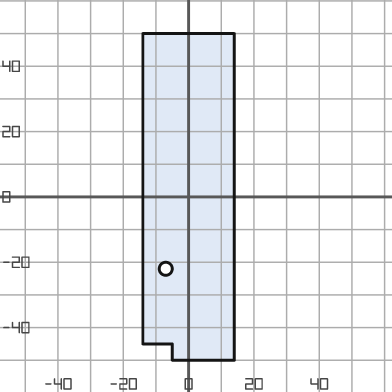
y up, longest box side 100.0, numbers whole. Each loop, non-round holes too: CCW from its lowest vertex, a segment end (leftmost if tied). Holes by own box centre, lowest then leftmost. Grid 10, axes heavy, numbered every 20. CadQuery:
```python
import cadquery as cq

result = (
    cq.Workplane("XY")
    .moveTo(-5.0, -50.0)
    .lineTo(14.0, -50.0)
    .lineTo(14.0, 50.0)
    .lineTo(-14.0, 50.0)
    .lineTo(-14.0, -45.0)
    .lineTo(-5.0, -45.0)
    .close()
    .moveTo(-7.0, -22.0)
    .circle(2.0)
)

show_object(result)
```